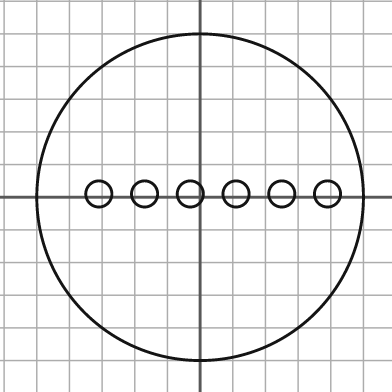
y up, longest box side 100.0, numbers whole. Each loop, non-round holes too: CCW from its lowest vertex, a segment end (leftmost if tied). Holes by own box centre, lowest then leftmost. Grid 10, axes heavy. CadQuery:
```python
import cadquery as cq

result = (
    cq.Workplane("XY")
    .moveTo(0.0, 0.0)
    .circle(50.0)
    .moveTo(-31.0, 1.0)
    .circle(4.0)
    .moveTo(-17.0, 1.0)
    .circle(4.0)
    .moveTo(-3.0, 1.0)
    .circle(4.0)
    .moveTo(11.0, 1.0)
    .circle(4.0)
    .moveTo(25.0, 1.0)
    .circle(4.0)
    .moveTo(39.0, 1.0)
    .circle(4.0)
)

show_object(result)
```